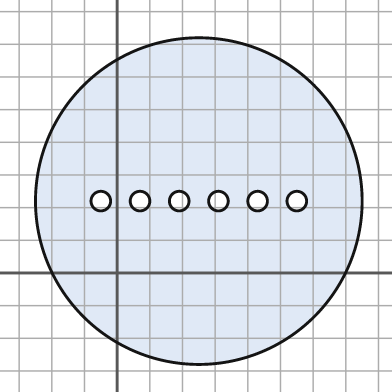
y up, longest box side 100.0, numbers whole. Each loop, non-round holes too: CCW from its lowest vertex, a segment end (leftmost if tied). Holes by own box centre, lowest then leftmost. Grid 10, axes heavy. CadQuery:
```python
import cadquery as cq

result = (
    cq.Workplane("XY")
    .moveTo(25.0, 22.0)
    .circle(50.0)
    .moveTo(-5.0, 22.0)
    .circle(3.0)
    .moveTo(7.0, 22.0)
    .circle(3.0)
    .moveTo(19.0, 22.0)
    .circle(3.0)
    .moveTo(31.0, 22.0)
    .circle(3.0)
    .moveTo(43.0, 22.0)
    .circle(3.0)
    .moveTo(55.0, 22.0)
    .circle(3.0)
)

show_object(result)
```